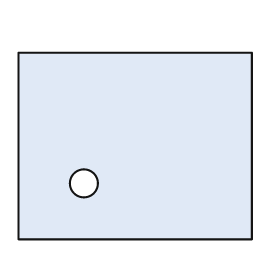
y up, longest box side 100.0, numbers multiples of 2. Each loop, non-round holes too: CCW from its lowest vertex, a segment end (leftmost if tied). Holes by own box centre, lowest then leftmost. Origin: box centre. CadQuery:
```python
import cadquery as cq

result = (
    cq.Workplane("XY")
    .moveTo(-50.0, -40.0)
    .lineTo(50.0, -40.0)
    .lineTo(50.0, 40.0)
    .lineTo(-50.0, 40.0)
    .close()
    .moveTo(-22.0, -16.0)
    .circle(6.0)
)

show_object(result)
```